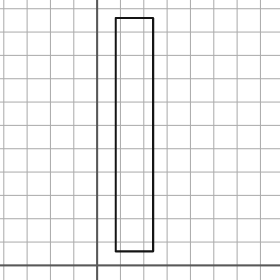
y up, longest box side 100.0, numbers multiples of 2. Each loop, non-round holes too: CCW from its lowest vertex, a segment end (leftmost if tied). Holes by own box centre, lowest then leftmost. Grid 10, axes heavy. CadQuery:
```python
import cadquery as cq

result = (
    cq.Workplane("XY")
    .moveTo(8.0, 6.0)
    .lineTo(24.0, 6.0)
    .lineTo(24.0, 106.0)
    .lineTo(8.0, 106.0)
    .close()
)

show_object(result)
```